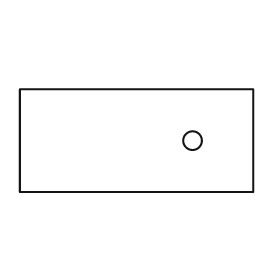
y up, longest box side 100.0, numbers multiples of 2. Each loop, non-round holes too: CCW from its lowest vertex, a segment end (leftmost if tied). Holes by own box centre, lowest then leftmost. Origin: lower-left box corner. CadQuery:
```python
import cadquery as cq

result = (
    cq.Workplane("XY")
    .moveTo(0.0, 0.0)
    .lineTo(100.0, 0.0)
    .lineTo(100.0, 44.0)
    .lineTo(0.0, 44.0)
    .close()
    .moveTo(74.0, 22.0)
    .circle(4.0)
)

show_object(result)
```